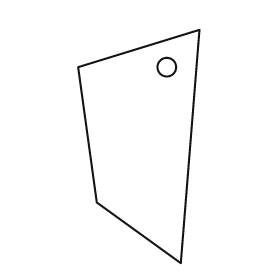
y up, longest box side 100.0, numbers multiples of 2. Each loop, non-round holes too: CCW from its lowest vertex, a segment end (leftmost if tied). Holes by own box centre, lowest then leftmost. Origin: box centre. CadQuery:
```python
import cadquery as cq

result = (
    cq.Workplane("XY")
    .moveTo(18.0, -50.0)
    .lineTo(26.0, 50.0)
    .lineTo(-26.0, 34.0)
    .lineTo(-18.0, -24.0)
    .close()
    .moveTo(12.0, 34.0)
    .circle(4.0)
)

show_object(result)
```